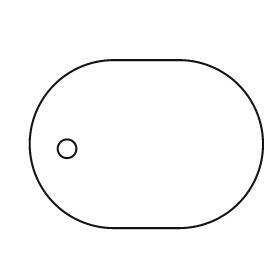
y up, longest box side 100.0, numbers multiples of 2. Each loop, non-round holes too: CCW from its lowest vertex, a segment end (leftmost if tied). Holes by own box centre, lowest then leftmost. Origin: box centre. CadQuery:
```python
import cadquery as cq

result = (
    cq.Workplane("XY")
    .moveTo(-14.0, -36.0)
    .lineTo(14.0, -36.0)
    .threePointArc((50.0, 0.0), (14.0, 36.0))
    .lineTo(-14.0, 36.0)
    .threePointArc((-50.0, 0.0), (-14.0, -36.0))
    .close()
    .moveTo(-34.0, -2.0)
    .circle(4.0)
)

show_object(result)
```